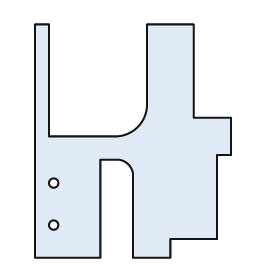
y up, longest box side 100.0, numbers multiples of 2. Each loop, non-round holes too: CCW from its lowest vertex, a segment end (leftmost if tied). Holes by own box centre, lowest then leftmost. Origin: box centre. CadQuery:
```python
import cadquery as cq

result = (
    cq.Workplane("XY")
    .moveTo(-42.0, -50.0)
    .lineTo(-14.0, -50.0)
    .lineTo(-14.0, -8.0)
    .lineTo(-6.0, -8.0)
    .threePointArc((-2.0, -10.0), (0.0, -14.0))
    .lineTo(0.0, -50.0)
    .lineTo(16.0, -50.0)
    .lineTo(16.0, -42.0)
    .lineTo(36.0, -42.0)
    .lineTo(36.0, -6.0)
    .lineTo(42.0, -6.0)
    .lineTo(42.0, 10.0)
    .lineTo(26.0, 10.0)
    .lineTo(26.0, 50.0)
    .lineTo(6.0, 50.0)
    .lineTo(6.0, 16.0)
    .threePointArc((2.0, 6.0), (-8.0, 2.0))
    .lineTo(-36.0, 2.0)
    .lineTo(-36.0, 50.0)
    .lineTo(-42.0, 50.0)
    .close()
    .moveTo(-34.0, -36.0)
    .circle(2.0)
    .moveTo(-34.0, -18.0)
    .circle(2.0)
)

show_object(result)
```